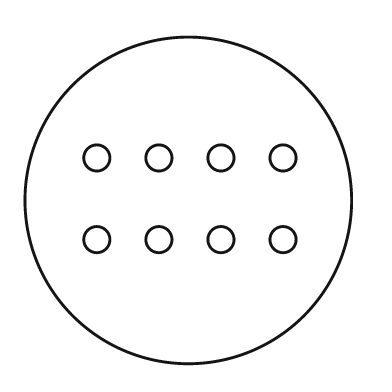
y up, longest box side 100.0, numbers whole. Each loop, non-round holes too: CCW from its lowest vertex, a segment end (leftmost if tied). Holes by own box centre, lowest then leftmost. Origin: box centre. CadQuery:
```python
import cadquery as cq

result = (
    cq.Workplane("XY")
    .moveTo(0.0, 0.0)
    .circle(50.0)
    .moveTo(-28.0, -12.0)
    .circle(4.0)
    .moveTo(-9.0, -12.0)
    .circle(4.0)
    .moveTo(10.0, -12.0)
    .circle(4.0)
    .moveTo(29.0, -12.0)
    .circle(4.0)
    .moveTo(-28.0, 13.0)
    .circle(4.0)
    .moveTo(-9.0, 13.0)
    .circle(4.0)
    .moveTo(10.0, 13.0)
    .circle(4.0)
    .moveTo(29.0, 13.0)
    .circle(4.0)
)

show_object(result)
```